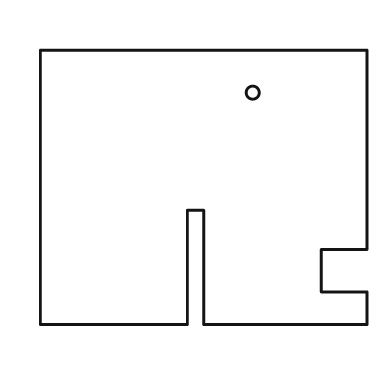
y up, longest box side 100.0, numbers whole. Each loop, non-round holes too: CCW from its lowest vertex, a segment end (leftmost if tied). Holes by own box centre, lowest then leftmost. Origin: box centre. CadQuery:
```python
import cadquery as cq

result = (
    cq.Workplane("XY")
    .moveTo(-50.0, -42.0)
    .lineTo(-5.0, -42.0)
    .lineTo(-5.0, -7.0)
    .lineTo(0.0, -7.0)
    .lineTo(0.0, -42.0)
    .lineTo(50.0, -42.0)
    .lineTo(50.0, -32.0)
    .lineTo(36.0, -32.0)
    .lineTo(36.0, -19.0)
    .lineTo(50.0, -19.0)
    .lineTo(50.0, 42.0)
    .lineTo(-50.0, 42.0)
    .close()
    .moveTo(15.0, 29.0)
    .circle(2.0)
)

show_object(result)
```